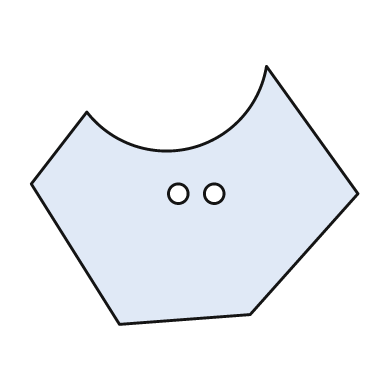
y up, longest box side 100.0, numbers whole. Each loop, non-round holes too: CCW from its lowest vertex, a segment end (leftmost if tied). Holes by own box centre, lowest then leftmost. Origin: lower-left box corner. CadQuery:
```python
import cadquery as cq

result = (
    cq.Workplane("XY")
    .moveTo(27.0, 0.0)
    .lineTo(67.0, 3.0)
    .lineTo(100.0, 40.0)
    .lineTo(72.0, 79.0)
    .threePointArc((49.0, 54.0), (17.0, 65.0))
    .lineTo(0.0, 43.0)
    .close()
    .moveTo(45.0, 40.0)
    .circle(3.0)
    .moveTo(56.0, 40.0)
    .circle(3.0)
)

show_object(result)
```